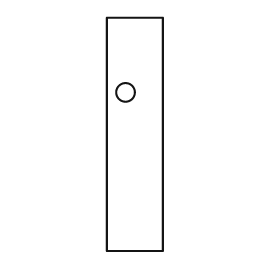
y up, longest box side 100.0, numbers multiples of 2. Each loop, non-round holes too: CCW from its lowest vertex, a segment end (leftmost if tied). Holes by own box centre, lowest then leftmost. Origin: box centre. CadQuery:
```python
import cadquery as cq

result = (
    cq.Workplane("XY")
    .moveTo(-12.0, -50.0)
    .lineTo(12.0, -50.0)
    .lineTo(12.0, 50.0)
    .lineTo(-12.0, 50.0)
    .close()
    .moveTo(-4.0, 18.0)
    .circle(4.0)
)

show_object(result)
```